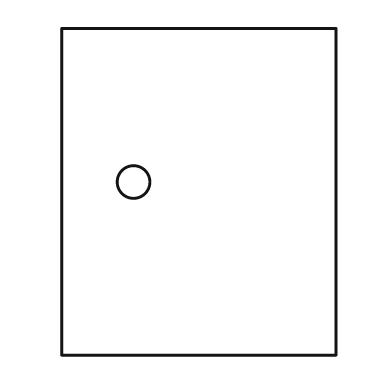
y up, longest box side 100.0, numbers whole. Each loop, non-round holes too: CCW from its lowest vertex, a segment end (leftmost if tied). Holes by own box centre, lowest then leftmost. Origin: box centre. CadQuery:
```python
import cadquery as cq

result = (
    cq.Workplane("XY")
    .moveTo(-42.0, -50.0)
    .lineTo(42.0, -50.0)
    .lineTo(42.0, 50.0)
    .lineTo(-42.0, 50.0)
    .close()
    .moveTo(-20.0, 3.0)
    .circle(5.0)
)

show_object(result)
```